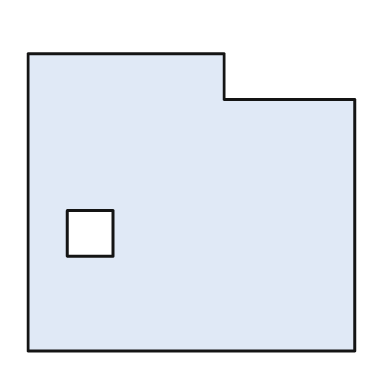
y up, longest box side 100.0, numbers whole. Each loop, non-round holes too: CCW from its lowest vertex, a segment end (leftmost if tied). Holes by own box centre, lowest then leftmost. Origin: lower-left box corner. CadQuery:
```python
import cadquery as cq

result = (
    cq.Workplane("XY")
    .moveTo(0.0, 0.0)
    .lineTo(100.0, 0.0)
    .lineTo(100.0, 77.0)
    .lineTo(60.0, 77.0)
    .lineTo(60.0, 91.0)
    .lineTo(0.0, 91.0)
    .close()
    .moveTo(12.0, 29.0)
    .lineTo(26.0, 29.0)
    .lineTo(26.0, 43.0)
    .lineTo(12.0, 43.0)
    .close()
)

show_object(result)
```